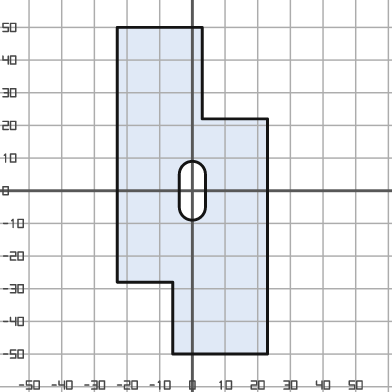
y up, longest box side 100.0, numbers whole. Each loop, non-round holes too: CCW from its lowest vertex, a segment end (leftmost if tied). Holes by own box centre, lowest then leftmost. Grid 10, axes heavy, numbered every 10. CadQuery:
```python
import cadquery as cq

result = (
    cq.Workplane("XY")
    .moveTo(-6.0, -50.0)
    .lineTo(23.0, -50.0)
    .lineTo(23.0, 22.0)
    .lineTo(3.0, 22.0)
    .lineTo(3.0, 50.0)
    .lineTo(-23.0, 50.0)
    .lineTo(-23.0, -28.0)
    .lineTo(-6.0, -28.0)
    .close()
    .moveTo(-4.0, -5.0)
    .threePointArc((0.0, -9.0), (4.0, -5.0))
    .lineTo(4.0, 5.0)
    .threePointArc((0.0, 9.0), (-4.0, 5.0))
    .close()
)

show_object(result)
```